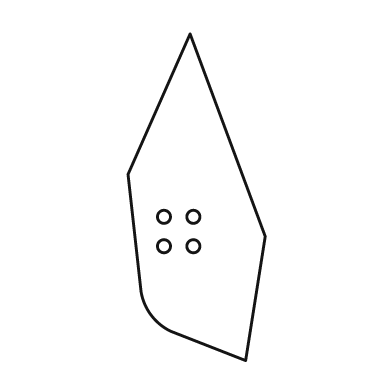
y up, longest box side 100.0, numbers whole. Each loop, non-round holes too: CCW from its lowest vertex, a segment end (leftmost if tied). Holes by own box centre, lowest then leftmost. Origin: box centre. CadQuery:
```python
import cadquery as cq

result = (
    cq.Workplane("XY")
    .moveTo(15.0, -50.0)
    .lineTo(21.0, -12.0)
    .lineTo(-2.0, 50.0)
    .lineTo(-21.0, 7.0)
    .lineTo(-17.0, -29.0)
    .threePointArc((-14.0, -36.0), (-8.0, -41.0))
    .close()
    .moveTo(-10.0, -15.0)
    .circle(2.0)
    .moveTo(-1.0, -15.0)
    .circle(2.0)
    .moveTo(-10.0, -6.0)
    .circle(2.0)
    .moveTo(-1.0, -6.0)
    .circle(2.0)
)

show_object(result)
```